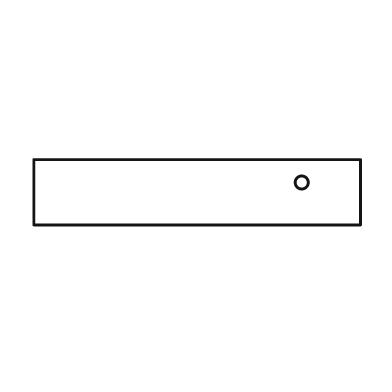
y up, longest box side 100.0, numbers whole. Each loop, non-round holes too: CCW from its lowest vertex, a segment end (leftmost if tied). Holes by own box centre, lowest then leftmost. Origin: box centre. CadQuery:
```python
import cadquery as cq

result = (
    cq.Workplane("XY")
    .moveTo(-50.0, -10.0)
    .lineTo(50.0, -10.0)
    .lineTo(50.0, 10.0)
    .lineTo(-50.0, 10.0)
    .close()
    .moveTo(32.0, 3.0)
    .circle(2.0)
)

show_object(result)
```